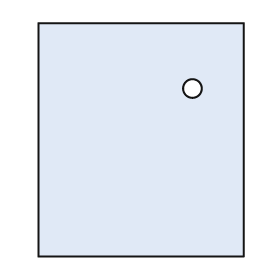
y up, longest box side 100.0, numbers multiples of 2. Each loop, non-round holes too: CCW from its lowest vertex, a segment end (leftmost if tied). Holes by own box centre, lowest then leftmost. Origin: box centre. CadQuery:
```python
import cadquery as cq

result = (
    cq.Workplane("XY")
    .moveTo(-44.0, -50.0)
    .lineTo(44.0, -50.0)
    .lineTo(44.0, 50.0)
    .lineTo(-44.0, 50.0)
    .close()
    .moveTo(22.0, 22.0)
    .circle(4.0)
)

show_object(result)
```